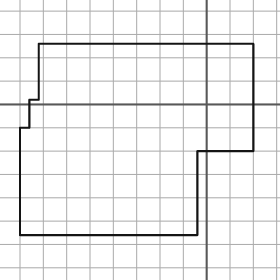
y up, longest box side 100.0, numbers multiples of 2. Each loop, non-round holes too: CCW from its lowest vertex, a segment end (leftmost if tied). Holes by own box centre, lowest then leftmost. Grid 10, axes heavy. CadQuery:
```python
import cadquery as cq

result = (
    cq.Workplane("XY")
    .moveTo(-80.0, -56.0)
    .lineTo(-4.0, -56.0)
    .lineTo(-4.0, -20.0)
    .lineTo(20.0, -20.0)
    .lineTo(20.0, 26.0)
    .lineTo(-72.0, 26.0)
    .lineTo(-72.0, 2.0)
    .lineTo(-76.0, 2.0)
    .lineTo(-76.0, -10.0)
    .lineTo(-80.0, -10.0)
    .close()
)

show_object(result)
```